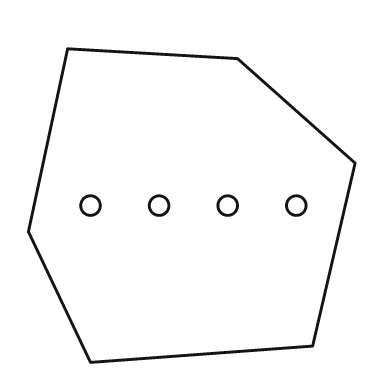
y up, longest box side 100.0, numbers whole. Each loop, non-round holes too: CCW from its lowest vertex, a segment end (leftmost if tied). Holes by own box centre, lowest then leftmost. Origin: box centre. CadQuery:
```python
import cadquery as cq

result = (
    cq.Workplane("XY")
    .moveTo(-31.0, -48.0)
    .lineTo(37.0, -43.0)
    .lineTo(50.0, 13.0)
    .lineTo(14.0, 45.0)
    .lineTo(-38.0, 48.0)
    .lineTo(-50.0, -8.0)
    .close()
    .moveTo(-31.0, 0.0)
    .circle(3.0)
    .moveTo(-10.0, 0.0)
    .circle(3.0)
    .moveTo(11.0, 0.0)
    .circle(3.0)
    .moveTo(32.0, 0.0)
    .circle(3.0)
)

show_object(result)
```